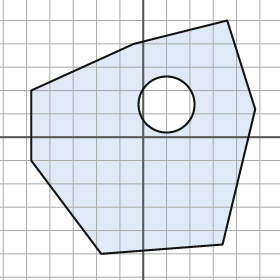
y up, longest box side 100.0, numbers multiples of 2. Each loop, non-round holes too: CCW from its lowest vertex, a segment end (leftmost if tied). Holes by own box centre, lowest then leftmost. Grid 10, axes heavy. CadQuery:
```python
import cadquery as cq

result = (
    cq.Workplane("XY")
    .moveTo(-18.0, -50.0)
    .lineTo(34.0, -46.0)
    .lineTo(48.0, 12.0)
    .lineTo(36.0, 50.0)
    .lineTo(-4.0, 40.0)
    .lineTo(-48.0, 20.0)
    .lineTo(-48.0, -10.0)
    .close()
    .moveTo(10.0, 14.0)
    .circle(12.0)
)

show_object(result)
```